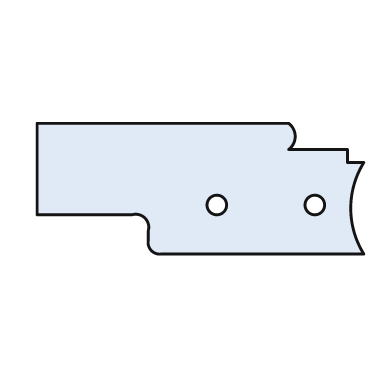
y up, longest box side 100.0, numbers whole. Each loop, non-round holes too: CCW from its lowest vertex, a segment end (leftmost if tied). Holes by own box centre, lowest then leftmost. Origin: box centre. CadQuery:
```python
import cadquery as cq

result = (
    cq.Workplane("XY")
    .moveTo(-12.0, -20.0)
    .lineTo(50.0, -20.0)
    .threePointArc((46.0, -6.0), (50.0, 8.0))
    .lineTo(45.0, 8.0)
    .lineTo(45.0, 12.0)
    .lineTo(27.0, 12.0)
    .threePointArc((29.0, 16.0), (27.0, 20.0))
    .lineTo(-50.0, 20.0)
    .lineTo(-50.0, -8.0)
    .lineTo(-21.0, -8.0)
    .threePointArc((-17.0, -9.0), (-16.0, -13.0))
    .lineTo(-16.0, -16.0)
    .threePointArc((-15.0, -19.0), (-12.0, -20.0))
    .close()
    .moveTo(5.0, -5.0)
    .circle(3.0)
    .moveTo(35.0, -5.0)
    .circle(3.0)
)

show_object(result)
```